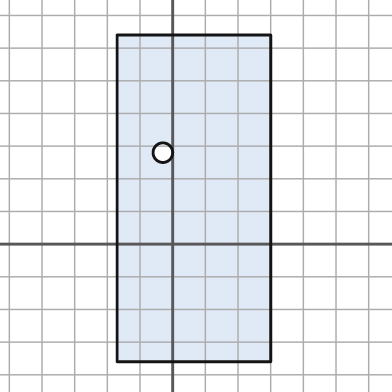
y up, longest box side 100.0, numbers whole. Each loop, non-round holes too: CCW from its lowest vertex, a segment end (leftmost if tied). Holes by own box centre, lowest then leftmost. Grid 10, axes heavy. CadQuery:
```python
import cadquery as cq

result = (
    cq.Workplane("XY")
    .moveTo(-17.0, -36.0)
    .lineTo(30.0, -36.0)
    .lineTo(30.0, 64.0)
    .lineTo(-17.0, 64.0)
    .close()
    .moveTo(-3.0, 28.0)
    .circle(3.0)
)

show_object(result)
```